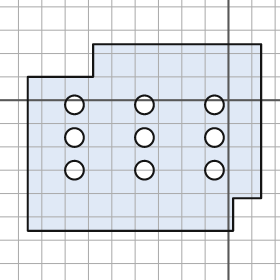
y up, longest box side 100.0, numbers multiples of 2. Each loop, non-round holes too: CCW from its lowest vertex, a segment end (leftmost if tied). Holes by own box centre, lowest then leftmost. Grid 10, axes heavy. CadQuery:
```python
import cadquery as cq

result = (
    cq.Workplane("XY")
    .moveTo(-86.0, -56.0)
    .lineTo(2.0, -56.0)
    .lineTo(2.0, -42.0)
    .lineTo(14.0, -42.0)
    .lineTo(14.0, 24.0)
    .lineTo(-58.0, 24.0)
    .lineTo(-58.0, 10.0)
    .lineTo(-86.0, 10.0)
    .close()
    .moveTo(-66.0, -30.0)
    .circle(4.0)
    .moveTo(-36.0, -30.0)
    .circle(4.0)
    .moveTo(-6.0, -30.0)
    .circle(4.0)
    .moveTo(-66.0, -16.0)
    .circle(4.0)
    .moveTo(-36.0, -16.0)
    .circle(4.0)
    .moveTo(-6.0, -16.0)
    .circle(4.0)
    .moveTo(-66.0, -2.0)
    .circle(4.0)
    .moveTo(-36.0, -2.0)
    .circle(4.0)
    .moveTo(-6.0, -2.0)
    .circle(4.0)
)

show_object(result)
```